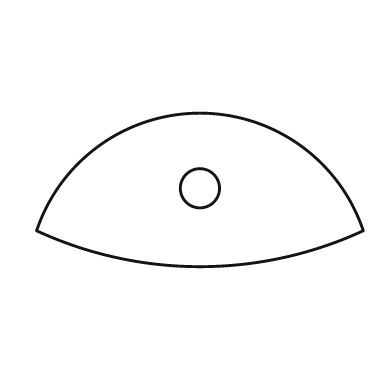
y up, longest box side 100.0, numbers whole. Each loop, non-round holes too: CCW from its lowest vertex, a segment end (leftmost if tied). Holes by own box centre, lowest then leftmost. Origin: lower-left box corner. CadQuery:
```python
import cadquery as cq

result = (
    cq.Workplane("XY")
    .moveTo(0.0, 11.0)
    .threePointArc((50.0, 0.0), (100.0, 11.0))
    .threePointArc((50.0, 47.0), (0.0, 11.0))
    .close()
    .moveTo(50.0, 24.0)
    .circle(6.0)
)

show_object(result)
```